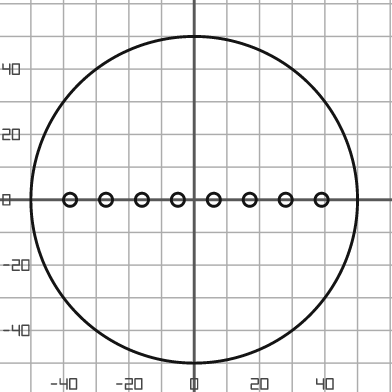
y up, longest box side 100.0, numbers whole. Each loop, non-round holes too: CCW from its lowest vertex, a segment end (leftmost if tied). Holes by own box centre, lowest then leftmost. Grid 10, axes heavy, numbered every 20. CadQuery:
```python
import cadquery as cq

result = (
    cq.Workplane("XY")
    .moveTo(0.0, 0.0)
    .circle(50.0)
    .moveTo(-38.0, 0.0)
    .circle(2.0)
    .moveTo(-27.0, 0.0)
    .circle(2.0)
    .moveTo(-16.0, 0.0)
    .circle(2.0)
    .moveTo(-5.0, 0.0)
    .circle(2.0)
    .moveTo(6.0, 0.0)
    .circle(2.0)
    .moveTo(17.0, 0.0)
    .circle(2.0)
    .moveTo(28.0, 0.0)
    .circle(2.0)
    .moveTo(39.0, 0.0)
    .circle(2.0)
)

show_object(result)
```